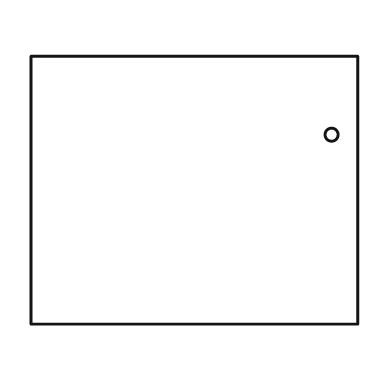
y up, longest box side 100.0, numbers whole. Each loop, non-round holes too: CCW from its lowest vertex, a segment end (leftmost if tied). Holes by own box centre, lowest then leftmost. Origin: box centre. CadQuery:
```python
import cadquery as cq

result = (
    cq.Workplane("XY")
    .moveTo(-50.0, -41.0)
    .lineTo(50.0, -41.0)
    .lineTo(50.0, 41.0)
    .lineTo(-50.0, 41.0)
    .close()
    .moveTo(42.0, 17.0)
    .circle(2.0)
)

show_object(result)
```